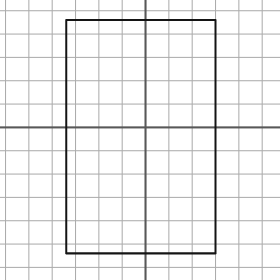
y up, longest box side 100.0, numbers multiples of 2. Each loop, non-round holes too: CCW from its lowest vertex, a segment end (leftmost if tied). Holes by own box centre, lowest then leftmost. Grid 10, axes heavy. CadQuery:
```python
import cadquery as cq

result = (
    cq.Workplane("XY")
    .moveTo(-34.0, -54.0)
    .lineTo(30.0, -54.0)
    .lineTo(30.0, 46.0)
    .lineTo(-34.0, 46.0)
    .close()
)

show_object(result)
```